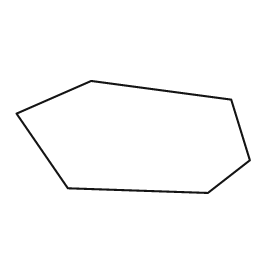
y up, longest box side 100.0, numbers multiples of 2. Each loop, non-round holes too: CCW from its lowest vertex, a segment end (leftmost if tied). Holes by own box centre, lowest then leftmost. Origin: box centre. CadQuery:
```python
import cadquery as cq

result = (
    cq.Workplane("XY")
    .moveTo(32.0, -24.0)
    .lineTo(50.0, -10.0)
    .lineTo(42.0, 16.0)
    .lineTo(-18.0, 24.0)
    .lineTo(-50.0, 10.0)
    .lineTo(-28.0, -22.0)
    .close()
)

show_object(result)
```